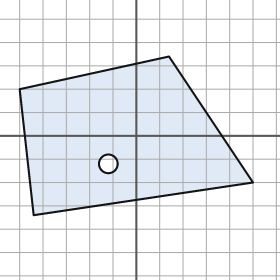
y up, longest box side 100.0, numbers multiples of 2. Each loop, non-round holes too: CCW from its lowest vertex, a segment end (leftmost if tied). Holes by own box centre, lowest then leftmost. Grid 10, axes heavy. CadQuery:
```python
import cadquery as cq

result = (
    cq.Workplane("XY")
    .moveTo(-44.0, -34.0)
    .lineTo(50.0, -20.0)
    .lineTo(14.0, 34.0)
    .lineTo(-50.0, 20.0)
    .close()
    .moveTo(-12.0, -12.0)
    .circle(4.0)
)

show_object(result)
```